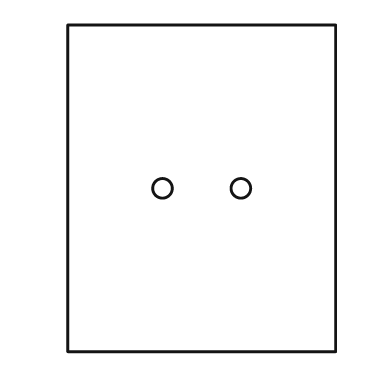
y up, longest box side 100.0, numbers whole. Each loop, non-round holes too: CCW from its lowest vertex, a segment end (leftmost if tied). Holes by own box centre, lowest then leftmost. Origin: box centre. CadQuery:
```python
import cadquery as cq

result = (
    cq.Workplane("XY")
    .moveTo(-41.0, -50.0)
    .lineTo(41.0, -50.0)
    .lineTo(41.0, 50.0)
    .lineTo(-41.0, 50.0)
    .close()
    .moveTo(-12.0, 0.0)
    .circle(3.0)
    .moveTo(12.0, 0.0)
    .circle(3.0)
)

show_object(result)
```